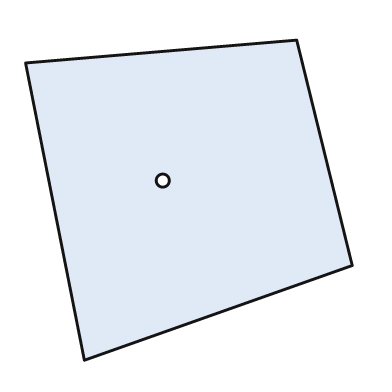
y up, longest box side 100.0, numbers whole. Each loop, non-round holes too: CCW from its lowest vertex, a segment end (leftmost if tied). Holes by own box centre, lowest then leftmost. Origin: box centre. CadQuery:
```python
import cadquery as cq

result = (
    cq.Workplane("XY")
    .moveTo(-32.0, -49.0)
    .lineTo(50.0, -20.0)
    .lineTo(33.0, 49.0)
    .lineTo(-50.0, 42.0)
    .close()
    .moveTo(-8.0, 6.0)
    .circle(2.0)
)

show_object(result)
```